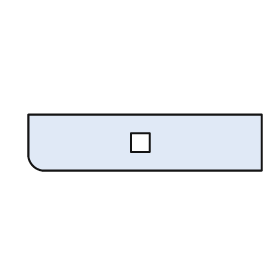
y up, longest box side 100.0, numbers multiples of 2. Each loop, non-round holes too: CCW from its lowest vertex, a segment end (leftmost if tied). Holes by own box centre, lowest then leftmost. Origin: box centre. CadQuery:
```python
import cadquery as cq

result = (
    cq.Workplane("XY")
    .moveTo(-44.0, -12.0)
    .lineTo(50.0, -12.0)
    .lineTo(50.0, 12.0)
    .lineTo(-50.0, 12.0)
    .lineTo(-50.0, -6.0)
    .threePointArc((-48.0, -10.0), (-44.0, -12.0))
    .close()
    .moveTo(-6.0, -4.0)
    .lineTo(2.0, -4.0)
    .lineTo(2.0, 4.0)
    .lineTo(-6.0, 4.0)
    .close()
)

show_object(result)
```